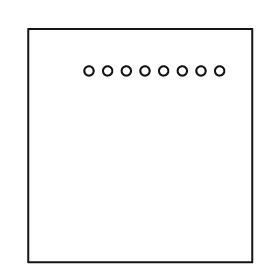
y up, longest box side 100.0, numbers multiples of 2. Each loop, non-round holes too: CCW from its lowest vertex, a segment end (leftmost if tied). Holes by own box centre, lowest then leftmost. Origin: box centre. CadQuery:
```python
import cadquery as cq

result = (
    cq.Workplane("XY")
    .moveTo(-48.0, -50.0)
    .lineTo(48.0, -50.0)
    .lineTo(48.0, 50.0)
    .lineTo(-48.0, 50.0)
    .close()
    .moveTo(-22.0, 32.0)
    .circle(2.0)
    .moveTo(-14.0, 32.0)
    .circle(2.0)
    .moveTo(-6.0, 32.0)
    .circle(2.0)
    .moveTo(2.0, 32.0)
    .circle(2.0)
    .moveTo(10.0, 32.0)
    .circle(2.0)
    .moveTo(18.0, 32.0)
    .circle(2.0)
    .moveTo(26.0, 32.0)
    .circle(2.0)
    .moveTo(34.0, 32.0)
    .circle(2.0)
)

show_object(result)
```